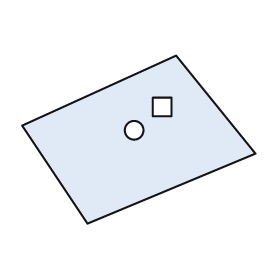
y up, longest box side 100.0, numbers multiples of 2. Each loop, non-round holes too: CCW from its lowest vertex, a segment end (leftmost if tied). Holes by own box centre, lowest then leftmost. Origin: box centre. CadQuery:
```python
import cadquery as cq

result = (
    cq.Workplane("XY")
    .moveTo(-22.0, -36.0)
    .lineTo(50.0, -6.0)
    .lineTo(16.0, 36.0)
    .lineTo(-50.0, 6.0)
    .close()
    .moveTo(-2.0, 4.0)
    .circle(4.0)
    .moveTo(6.0, 10.0)
    .lineTo(14.0, 10.0)
    .lineTo(14.0, 18.0)
    .lineTo(6.0, 18.0)
    .close()
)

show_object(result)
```